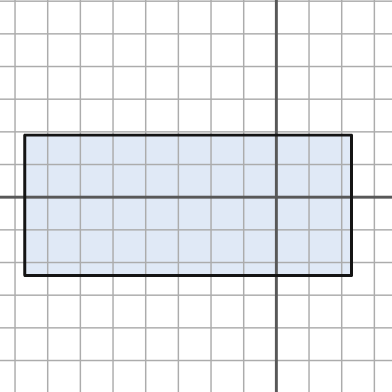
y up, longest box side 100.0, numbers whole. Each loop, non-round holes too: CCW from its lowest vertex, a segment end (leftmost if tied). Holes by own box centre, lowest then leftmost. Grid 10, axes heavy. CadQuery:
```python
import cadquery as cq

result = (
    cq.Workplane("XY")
    .moveTo(-77.0, -24.0)
    .lineTo(23.0, -24.0)
    .lineTo(23.0, 19.0)
    .lineTo(-77.0, 19.0)
    .close()
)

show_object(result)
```